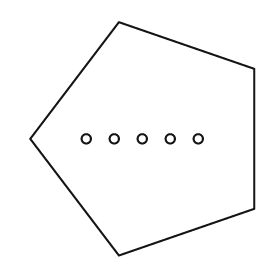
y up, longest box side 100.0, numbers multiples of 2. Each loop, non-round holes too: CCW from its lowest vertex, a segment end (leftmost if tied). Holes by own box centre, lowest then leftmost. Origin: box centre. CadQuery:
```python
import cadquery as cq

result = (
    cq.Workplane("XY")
    .moveTo(-10.0, -50.0)
    .lineTo(48.0, -30.0)
    .lineTo(48.0, 30.0)
    .lineTo(-10.0, 50.0)
    .lineTo(-48.0, 0.0)
    .close()
    .moveTo(-24.0, 0.0)
    .circle(2.0)
    .moveTo(-12.0, 0.0)
    .circle(2.0)
    .moveTo(0.0, 0.0)
    .circle(2.0)
    .moveTo(12.0, 0.0)
    .circle(2.0)
    .moveTo(24.0, 0.0)
    .circle(2.0)
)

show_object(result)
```